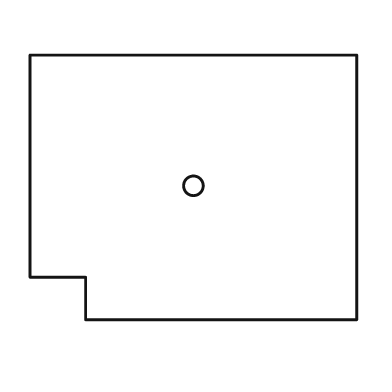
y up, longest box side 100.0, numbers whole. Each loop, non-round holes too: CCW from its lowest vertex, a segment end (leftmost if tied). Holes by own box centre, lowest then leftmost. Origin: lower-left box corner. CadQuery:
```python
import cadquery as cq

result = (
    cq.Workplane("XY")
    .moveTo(17.0, 0.0)
    .lineTo(100.0, 0.0)
    .lineTo(100.0, 81.0)
    .lineTo(0.0, 81.0)
    .lineTo(0.0, 13.0)
    .lineTo(17.0, 13.0)
    .close()
    .moveTo(50.0, 41.0)
    .circle(3.0)
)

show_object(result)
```